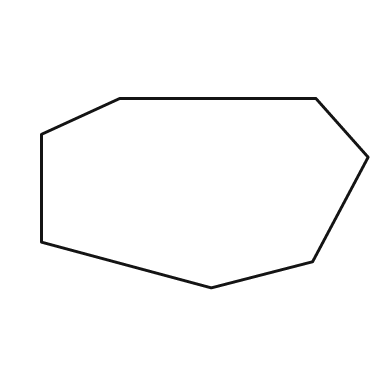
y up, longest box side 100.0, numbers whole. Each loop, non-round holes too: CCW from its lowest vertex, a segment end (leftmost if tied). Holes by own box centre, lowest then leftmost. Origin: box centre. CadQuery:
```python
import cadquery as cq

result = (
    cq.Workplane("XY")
    .moveTo(2.0, -29.0)
    .lineTo(33.0, -21.0)
    .lineTo(50.0, 11.0)
    .lineTo(34.0, 29.0)
    .lineTo(-26.0, 29.0)
    .lineTo(-50.0, 18.0)
    .lineTo(-50.0, -15.0)
    .close()
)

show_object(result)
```